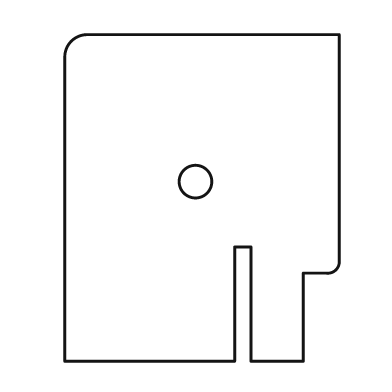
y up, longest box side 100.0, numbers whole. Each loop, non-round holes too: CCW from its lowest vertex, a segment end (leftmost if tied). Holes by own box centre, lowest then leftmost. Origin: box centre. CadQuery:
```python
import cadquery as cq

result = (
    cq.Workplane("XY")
    .moveTo(-42.0, -50.0)
    .lineTo(10.0, -50.0)
    .lineTo(10.0, -15.0)
    .lineTo(15.0, -15.0)
    .lineTo(15.0, -50.0)
    .lineTo(31.0, -50.0)
    .lineTo(31.0, -23.0)
    .lineTo(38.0, -23.0)
    .threePointArc((41.0, -22.0), (42.0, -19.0))
    .lineTo(42.0, 50.0)
    .lineTo(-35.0, 50.0)
    .threePointArc((-40.0, 48.0), (-42.0, 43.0))
    .close()
    .moveTo(-2.0, 5.0)
    .circle(5.0)
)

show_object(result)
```